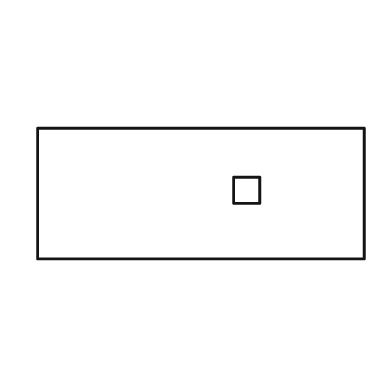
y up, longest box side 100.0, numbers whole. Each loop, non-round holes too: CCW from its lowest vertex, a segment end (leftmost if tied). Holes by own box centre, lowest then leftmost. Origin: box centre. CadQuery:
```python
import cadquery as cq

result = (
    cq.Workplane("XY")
    .moveTo(-50.0, -20.0)
    .lineTo(50.0, -20.0)
    .lineTo(50.0, 20.0)
    .lineTo(-50.0, 20.0)
    .close()
    .moveTo(10.0, -3.0)
    .lineTo(18.0, -3.0)
    .lineTo(18.0, 5.0)
    .lineTo(10.0, 5.0)
    .close()
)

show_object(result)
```